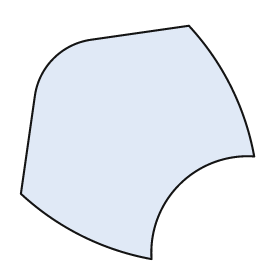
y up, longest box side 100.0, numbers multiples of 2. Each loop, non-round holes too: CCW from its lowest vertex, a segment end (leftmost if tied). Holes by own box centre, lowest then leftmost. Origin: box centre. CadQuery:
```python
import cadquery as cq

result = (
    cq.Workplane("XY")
    .moveTo(6.0, -50.0)
    .threePointArc((18.0, -18.0), (50.0, -6.0))
    .threePointArc((40.0, 24.0), (22.0, 50.0))
    .lineTo(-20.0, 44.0)
    .threePointArc((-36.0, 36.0), (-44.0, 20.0))
    .lineTo(-50.0, -22.0)
    .threePointArc((-24.0, -40.0), (6.0, -50.0))
    .close()
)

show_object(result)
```